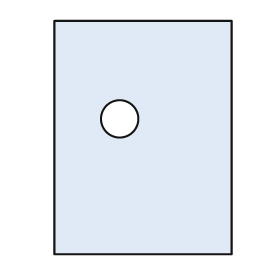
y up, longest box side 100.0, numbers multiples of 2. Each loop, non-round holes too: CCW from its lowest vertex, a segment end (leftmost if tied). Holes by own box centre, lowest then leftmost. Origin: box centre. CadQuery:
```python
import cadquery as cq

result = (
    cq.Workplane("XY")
    .moveTo(-38.0, -50.0)
    .lineTo(38.0, -50.0)
    .lineTo(38.0, 50.0)
    .lineTo(-38.0, 50.0)
    .close()
    .moveTo(-10.0, 8.0)
    .circle(8.0)
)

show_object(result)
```